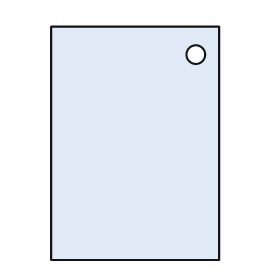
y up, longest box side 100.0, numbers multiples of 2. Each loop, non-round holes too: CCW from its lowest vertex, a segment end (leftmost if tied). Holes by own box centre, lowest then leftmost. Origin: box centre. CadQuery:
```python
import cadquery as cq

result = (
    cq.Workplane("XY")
    .moveTo(-36.0, -50.0)
    .lineTo(36.0, -50.0)
    .lineTo(36.0, 50.0)
    .lineTo(-36.0, 50.0)
    .close()
    .moveTo(26.0, 38.0)
    .circle(4.0)
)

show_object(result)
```